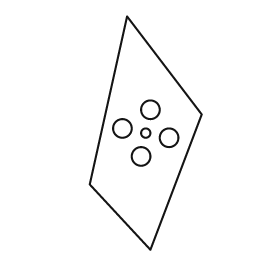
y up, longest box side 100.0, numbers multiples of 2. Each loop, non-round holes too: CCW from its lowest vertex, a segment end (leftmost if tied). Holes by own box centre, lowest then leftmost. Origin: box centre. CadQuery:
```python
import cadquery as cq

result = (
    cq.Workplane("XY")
    .moveTo(2.0, -50.0)
    .lineTo(24.0, 8.0)
    .lineTo(-8.0, 50.0)
    .lineTo(-24.0, -22.0)
    .close()
    .moveTo(-2.0, -10.0)
    .circle(4.0)
    .moveTo(10.0, -2.0)
    .circle(4.0)
    .moveTo(0.0, 0.0)
    .circle(2.0)
    .moveTo(-10.0, 2.0)
    .circle(4.0)
    .moveTo(2.0, 10.0)
    .circle(4.0)
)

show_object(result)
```